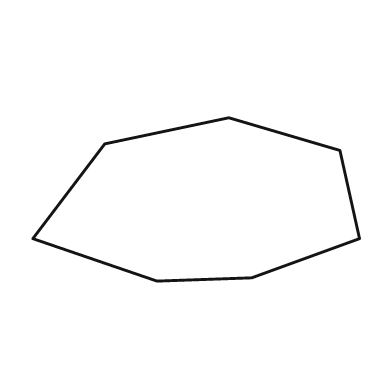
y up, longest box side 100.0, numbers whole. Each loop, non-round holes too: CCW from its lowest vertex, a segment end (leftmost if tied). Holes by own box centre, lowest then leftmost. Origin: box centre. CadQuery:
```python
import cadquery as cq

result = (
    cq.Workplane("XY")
    .moveTo(-12.0, -25.0)
    .lineTo(17.0, -24.0)
    .lineTo(50.0, -12.0)
    .lineTo(44.0, 15.0)
    .lineTo(10.0, 25.0)
    .lineTo(-28.0, 17.0)
    .lineTo(-50.0, -12.0)
    .close()
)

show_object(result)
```